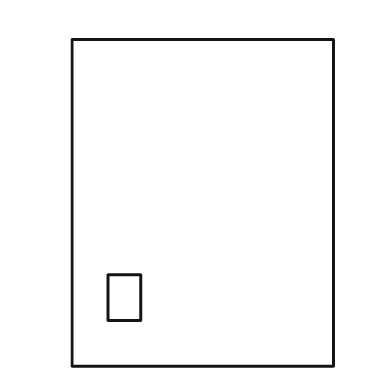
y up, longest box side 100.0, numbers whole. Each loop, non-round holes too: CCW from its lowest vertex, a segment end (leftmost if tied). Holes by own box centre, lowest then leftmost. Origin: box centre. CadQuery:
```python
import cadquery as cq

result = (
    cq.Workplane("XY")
    .moveTo(-40.0, -50.0)
    .lineTo(40.0, -50.0)
    .lineTo(40.0, 50.0)
    .lineTo(-40.0, 50.0)
    .close()
    .moveTo(-29.0, -36.0)
    .lineTo(-19.0, -36.0)
    .lineTo(-19.0, -22.0)
    .lineTo(-29.0, -22.0)
    .close()
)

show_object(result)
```